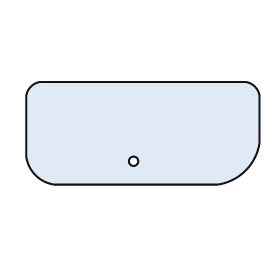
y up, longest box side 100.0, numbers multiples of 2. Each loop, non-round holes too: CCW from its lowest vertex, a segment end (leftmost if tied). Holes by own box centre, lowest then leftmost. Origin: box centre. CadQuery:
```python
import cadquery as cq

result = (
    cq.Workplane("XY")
    .moveTo(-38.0, -22.0)
    .lineTo(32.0, -22.0)
    .threePointArc((44.0, -16.0), (50.0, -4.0))
    .lineTo(50.0, 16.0)
    .threePointArc((48.0, 20.0), (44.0, 22.0))
    .lineTo(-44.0, 22.0)
    .threePointArc((-48.0, 20.0), (-50.0, 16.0))
    .lineTo(-50.0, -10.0)
    .threePointArc((-46.0, -18.0), (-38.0, -22.0))
    .close()
    .moveTo(-4.0, -12.0)
    .circle(2.0)
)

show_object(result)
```